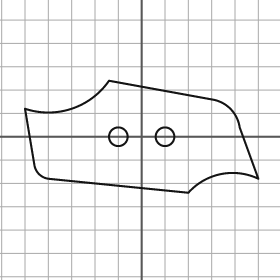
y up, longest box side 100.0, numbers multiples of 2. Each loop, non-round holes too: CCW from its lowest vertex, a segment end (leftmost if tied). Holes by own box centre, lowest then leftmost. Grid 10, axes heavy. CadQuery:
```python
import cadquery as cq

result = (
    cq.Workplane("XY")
    .moveTo(20.0, -24.0)
    .threePointArc((34.0, -16.0), (50.0, -18.0))
    .lineTo(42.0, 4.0)
    .threePointArc((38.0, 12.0), (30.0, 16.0))
    .lineTo(-14.0, 24.0)
    .threePointArc((-30.0, 12.0), (-50.0, 12.0))
    .lineTo(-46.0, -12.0)
    .threePointArc((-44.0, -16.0), (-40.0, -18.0))
    .close()
    .moveTo(-10.0, 0.0)
    .circle(4.0)
    .moveTo(10.0, 0.0)
    .circle(4.0)
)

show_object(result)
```